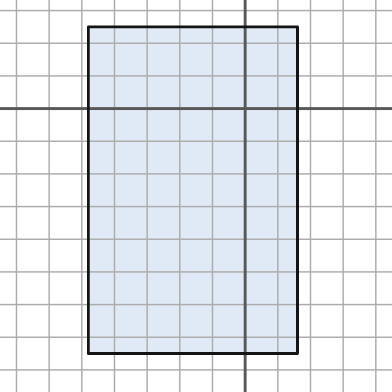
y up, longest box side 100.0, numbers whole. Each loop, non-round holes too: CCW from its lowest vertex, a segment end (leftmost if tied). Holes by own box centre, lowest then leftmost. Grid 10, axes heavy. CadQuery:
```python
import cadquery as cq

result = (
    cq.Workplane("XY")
    .moveTo(-48.0, -75.0)
    .lineTo(16.0, -75.0)
    .lineTo(16.0, 25.0)
    .lineTo(-48.0, 25.0)
    .close()
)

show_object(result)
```